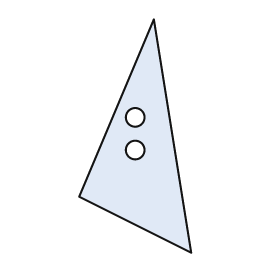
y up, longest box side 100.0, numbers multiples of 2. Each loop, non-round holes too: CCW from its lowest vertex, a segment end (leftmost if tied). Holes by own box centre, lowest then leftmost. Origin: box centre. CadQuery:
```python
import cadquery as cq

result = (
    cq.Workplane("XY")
    .moveTo(24.0, -50.0)
    .lineTo(8.0, 50.0)
    .lineTo(-24.0, -26.0)
    .close()
    .moveTo(0.0, -6.0)
    .circle(4.0)
    .moveTo(0.0, 8.0)
    .circle(4.0)
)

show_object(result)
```